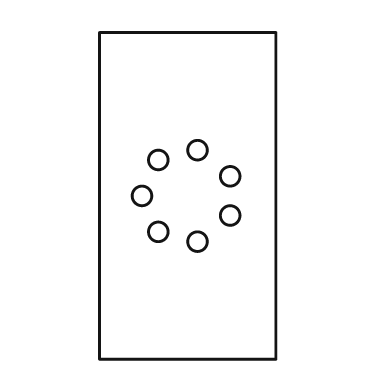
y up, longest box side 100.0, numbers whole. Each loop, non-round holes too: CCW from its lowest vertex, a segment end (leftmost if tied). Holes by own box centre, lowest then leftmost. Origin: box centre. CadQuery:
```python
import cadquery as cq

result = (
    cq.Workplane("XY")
    .moveTo(-27.0, -50.0)
    .lineTo(27.0, -50.0)
    .lineTo(27.0, 50.0)
    .lineTo(-27.0, 50.0)
    .close()
    .moveTo(3.0, -14.0)
    .circle(3.0)
    .moveTo(-9.0, -11.0)
    .circle(3.0)
    .moveTo(13.0, -6.0)
    .circle(3.0)
    .moveTo(-14.0, 0.0)
    .circle(3.0)
    .moveTo(13.0, 6.0)
    .circle(3.0)
    .moveTo(-9.0, 11.0)
    .circle(3.0)
    .moveTo(3.0, 14.0)
    .circle(3.0)
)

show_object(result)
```